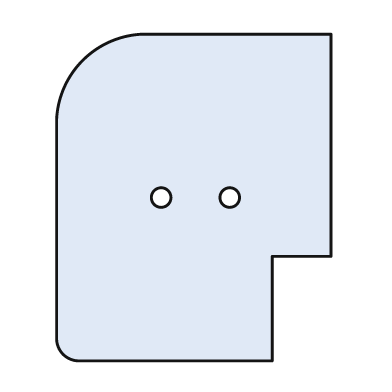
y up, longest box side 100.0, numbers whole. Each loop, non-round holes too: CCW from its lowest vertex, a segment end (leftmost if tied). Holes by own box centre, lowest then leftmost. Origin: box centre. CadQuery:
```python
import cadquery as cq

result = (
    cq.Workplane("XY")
    .moveTo(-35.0, -50.0)
    .lineTo(24.0, -50.0)
    .lineTo(24.0, -18.0)
    .lineTo(42.0, -18.0)
    .lineTo(42.0, 50.0)
    .lineTo(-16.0, 50.0)
    .threePointArc((-34.0, 42.0), (-42.0, 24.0))
    .lineTo(-42.0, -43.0)
    .threePointArc((-40.0, -48.0), (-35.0, -50.0))
    .close()
    .moveTo(-10.0, 0.0)
    .circle(3.0)
    .moveTo(11.0, 0.0)
    .circle(3.0)
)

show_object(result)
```